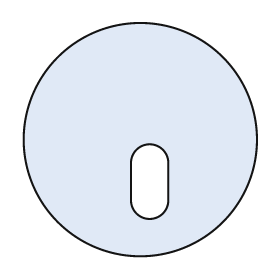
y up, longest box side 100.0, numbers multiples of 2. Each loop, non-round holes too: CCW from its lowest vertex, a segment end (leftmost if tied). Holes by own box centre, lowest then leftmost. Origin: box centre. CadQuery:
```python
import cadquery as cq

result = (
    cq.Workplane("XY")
    .moveTo(0.0, 0.0)
    .circle(50.0)
    .moveTo(-4.0, -26.0)
    .threePointArc((4.0, -34.0), (12.0, -26.0))
    .lineTo(12.0, -10.0)
    .threePointArc((4.0, -2.0), (-4.0, -10.0))
    .close()
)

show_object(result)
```